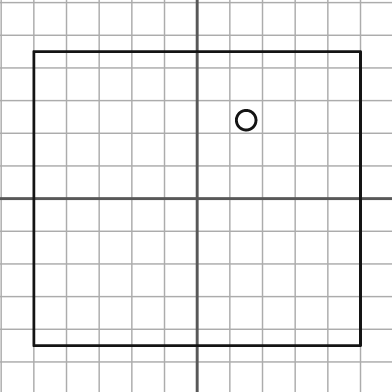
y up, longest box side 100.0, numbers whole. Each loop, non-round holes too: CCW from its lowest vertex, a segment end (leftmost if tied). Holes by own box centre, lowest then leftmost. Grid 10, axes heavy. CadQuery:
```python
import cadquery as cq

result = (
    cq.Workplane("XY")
    .moveTo(-50.0, -45.0)
    .lineTo(50.0, -45.0)
    .lineTo(50.0, 45.0)
    .lineTo(-50.0, 45.0)
    .close()
    .moveTo(15.0, 24.0)
    .circle(3.0)
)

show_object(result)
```